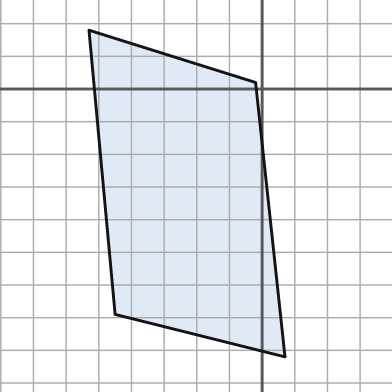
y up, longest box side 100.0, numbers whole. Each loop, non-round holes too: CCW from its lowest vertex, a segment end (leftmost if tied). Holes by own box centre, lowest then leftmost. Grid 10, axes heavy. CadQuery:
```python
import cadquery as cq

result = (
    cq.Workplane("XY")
    .moveTo(7.0, -82.0)
    .lineTo(-2.0, 2.0)
    .lineTo(-53.0, 18.0)
    .lineTo(-45.0, -69.0)
    .close()
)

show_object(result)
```